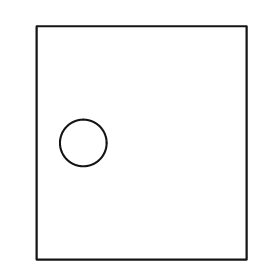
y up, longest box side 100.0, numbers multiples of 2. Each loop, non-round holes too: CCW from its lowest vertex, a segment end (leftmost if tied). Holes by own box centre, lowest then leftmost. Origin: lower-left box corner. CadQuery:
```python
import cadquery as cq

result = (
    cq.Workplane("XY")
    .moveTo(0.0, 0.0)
    .lineTo(90.0, 0.0)
    .lineTo(90.0, 100.0)
    .lineTo(0.0, 100.0)
    .close()
    .moveTo(20.0, 50.0)
    .circle(10.0)
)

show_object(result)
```